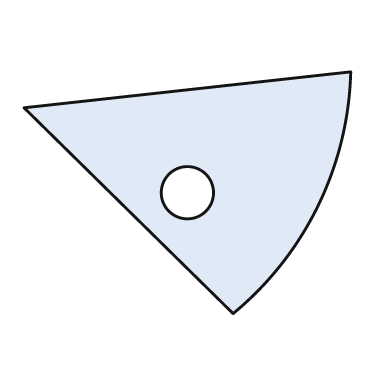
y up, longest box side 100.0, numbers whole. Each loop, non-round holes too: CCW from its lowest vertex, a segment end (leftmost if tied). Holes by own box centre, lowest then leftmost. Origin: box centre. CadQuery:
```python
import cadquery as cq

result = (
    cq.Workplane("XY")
    .moveTo(14.0, -37.0)
    .threePointArc((40.0, -4.0), (50.0, 37.0))
    .lineTo(-50.0, 26.0)
    .close()
    .moveTo(0.0, 0.0)
    .circle(8.0)
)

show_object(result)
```